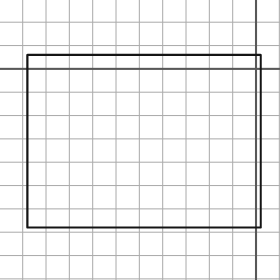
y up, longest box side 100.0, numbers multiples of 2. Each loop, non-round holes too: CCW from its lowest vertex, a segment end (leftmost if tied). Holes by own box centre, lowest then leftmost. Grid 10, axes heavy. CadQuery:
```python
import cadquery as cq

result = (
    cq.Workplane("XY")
    .moveTo(-98.0, -68.0)
    .lineTo(2.0, -68.0)
    .lineTo(2.0, 6.0)
    .lineTo(-98.0, 6.0)
    .close()
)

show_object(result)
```